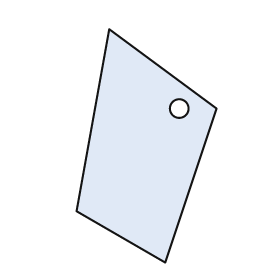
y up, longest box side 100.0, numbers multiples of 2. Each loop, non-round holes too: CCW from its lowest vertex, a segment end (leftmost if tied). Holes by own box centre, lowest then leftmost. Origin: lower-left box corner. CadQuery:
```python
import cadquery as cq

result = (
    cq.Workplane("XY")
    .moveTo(38.0, 0.0)
    .lineTo(60.0, 66.0)
    .lineTo(14.0, 100.0)
    .lineTo(0.0, 22.0)
    .close()
    .moveTo(44.0, 66.0)
    .circle(4.0)
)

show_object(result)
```